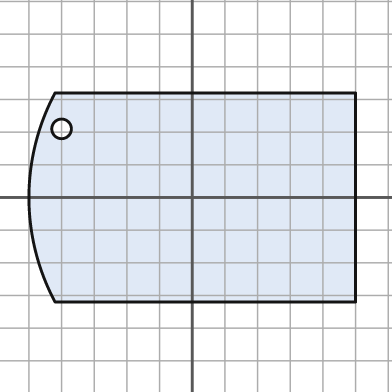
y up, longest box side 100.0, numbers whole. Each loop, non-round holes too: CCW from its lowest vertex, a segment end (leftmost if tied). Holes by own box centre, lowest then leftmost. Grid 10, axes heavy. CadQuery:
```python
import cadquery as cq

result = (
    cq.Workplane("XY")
    .moveTo(-42.0, -32.0)
    .lineTo(50.0, -32.0)
    .lineTo(50.0, 32.0)
    .lineTo(-42.0, 32.0)
    .threePointArc((-50.0, 0.0), (-42.0, -32.0))
    .close()
    .moveTo(-40.0, 21.0)
    .circle(3.0)
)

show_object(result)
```